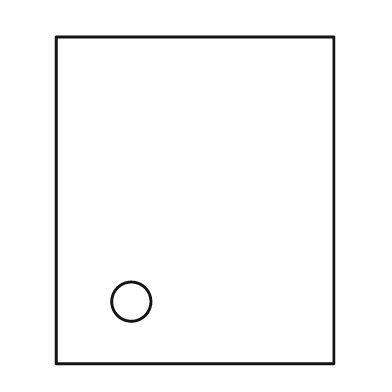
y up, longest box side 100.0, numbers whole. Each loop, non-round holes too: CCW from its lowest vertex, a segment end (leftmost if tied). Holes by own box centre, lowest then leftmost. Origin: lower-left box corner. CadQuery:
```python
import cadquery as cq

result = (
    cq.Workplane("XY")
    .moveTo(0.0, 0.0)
    .lineTo(85.0, 0.0)
    .lineTo(85.0, 100.0)
    .lineTo(0.0, 100.0)
    .close()
    .moveTo(23.0, 19.0)
    .circle(6.0)
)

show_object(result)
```